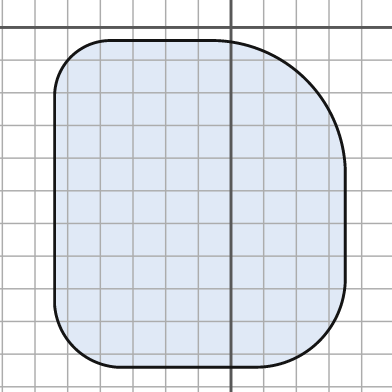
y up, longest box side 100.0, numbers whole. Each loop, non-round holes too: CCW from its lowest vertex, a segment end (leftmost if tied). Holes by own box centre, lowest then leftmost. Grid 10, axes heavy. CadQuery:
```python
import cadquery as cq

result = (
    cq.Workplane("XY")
    .moveTo(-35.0, -104.0)
    .lineTo(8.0, -104.0)
    .threePointArc((27.0, -96.0), (35.0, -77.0))
    .lineTo(35.0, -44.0)
    .threePointArc((23.0, -16.0), (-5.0, -4.0))
    .lineTo(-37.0, -4.0)
    .threePointArc((-49.0, -9.0), (-54.0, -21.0))
    .lineTo(-54.0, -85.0)
    .threePointArc((-48.0, -98.0), (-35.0, -104.0))
    .close()
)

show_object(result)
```